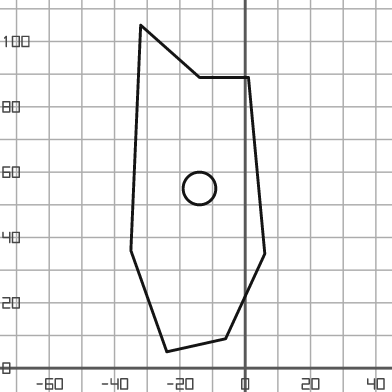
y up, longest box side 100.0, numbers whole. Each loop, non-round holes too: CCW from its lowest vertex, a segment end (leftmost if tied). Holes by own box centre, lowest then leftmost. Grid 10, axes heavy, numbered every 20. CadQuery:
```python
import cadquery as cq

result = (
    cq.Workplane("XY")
    .moveTo(-24.0, 5.0)
    .lineTo(-6.0, 9.0)
    .lineTo(6.0, 35.0)
    .lineTo(1.0, 89.0)
    .lineTo(-14.0, 89.0)
    .lineTo(-32.0, 105.0)
    .lineTo(-35.0, 36.0)
    .close()
    .moveTo(-14.0, 55.0)
    .circle(5.0)
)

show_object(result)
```